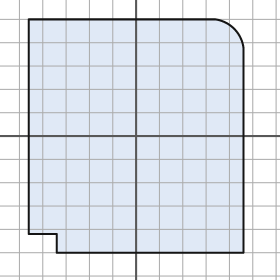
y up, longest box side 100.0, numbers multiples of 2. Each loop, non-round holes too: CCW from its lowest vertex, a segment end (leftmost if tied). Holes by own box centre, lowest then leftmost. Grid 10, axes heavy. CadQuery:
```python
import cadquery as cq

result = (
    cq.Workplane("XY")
    .moveTo(-34.0, -50.0)
    .lineTo(46.0, -50.0)
    .lineTo(46.0, 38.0)
    .threePointArc((42.0, 46.0), (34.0, 50.0))
    .lineTo(-46.0, 50.0)
    .lineTo(-46.0, -42.0)
    .lineTo(-34.0, -42.0)
    .close()
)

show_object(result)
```